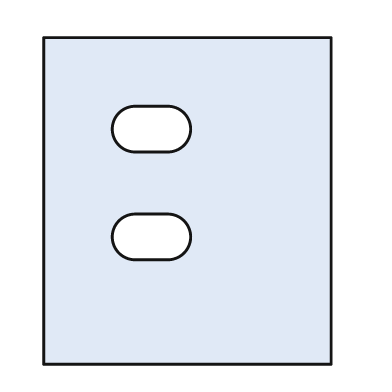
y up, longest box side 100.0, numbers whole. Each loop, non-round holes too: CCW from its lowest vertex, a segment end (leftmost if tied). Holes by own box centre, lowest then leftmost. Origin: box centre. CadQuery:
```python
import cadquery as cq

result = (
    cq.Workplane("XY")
    .moveTo(-44.0, -50.0)
    .lineTo(44.0, -50.0)
    .lineTo(44.0, 50.0)
    .lineTo(-44.0, 50.0)
    .close()
    .moveTo(-16.0, -18.0)
    .lineTo(-6.0, -18.0)
    .threePointArc((1.0, -11.0), (-6.0, -4.0))
    .lineTo(-16.0, -4.0)
    .threePointArc((-23.0, -11.0), (-16.0, -18.0))
    .close()
    .moveTo(-16.0, 15.0)
    .lineTo(-6.0, 15.0)
    .threePointArc((1.0, 22.0), (-6.0, 29.0))
    .lineTo(-16.0, 29.0)
    .threePointArc((-23.0, 22.0), (-16.0, 15.0))
    .close()
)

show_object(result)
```